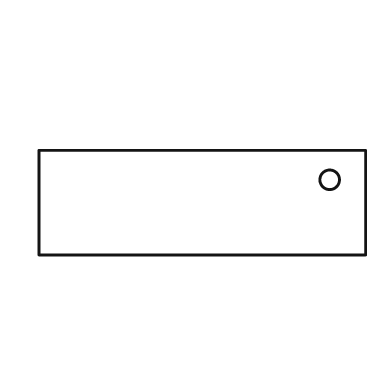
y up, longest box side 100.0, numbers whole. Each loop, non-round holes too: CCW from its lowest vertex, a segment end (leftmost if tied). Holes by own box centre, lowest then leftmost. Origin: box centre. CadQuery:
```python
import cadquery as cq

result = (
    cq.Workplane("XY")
    .moveTo(-50.0, -16.0)
    .lineTo(50.0, -16.0)
    .lineTo(50.0, 16.0)
    .lineTo(-50.0, 16.0)
    .close()
    .moveTo(39.0, 7.0)
    .circle(3.0)
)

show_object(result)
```